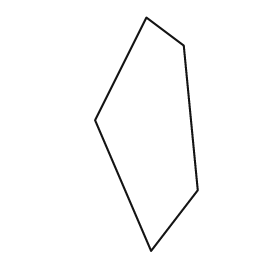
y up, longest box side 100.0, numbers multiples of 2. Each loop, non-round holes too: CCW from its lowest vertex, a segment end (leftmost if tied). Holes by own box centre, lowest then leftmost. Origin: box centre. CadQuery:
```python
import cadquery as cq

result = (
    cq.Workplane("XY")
    .moveTo(2.0, -50.0)
    .lineTo(22.0, -24.0)
    .lineTo(16.0, 38.0)
    .lineTo(0.0, 50.0)
    .lineTo(-22.0, 6.0)
    .close()
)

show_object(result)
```